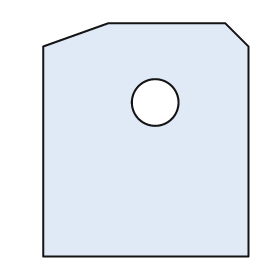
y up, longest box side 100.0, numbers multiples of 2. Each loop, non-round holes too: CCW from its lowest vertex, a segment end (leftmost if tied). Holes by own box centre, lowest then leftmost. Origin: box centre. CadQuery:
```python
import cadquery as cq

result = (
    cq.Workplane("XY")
    .moveTo(-44.0, -50.0)
    .lineTo(44.0, -50.0)
    .lineTo(44.0, 40.0)
    .lineTo(34.0, 50.0)
    .lineTo(-16.0, 50.0)
    .lineTo(-44.0, 40.0)
    .close()
    .moveTo(4.0, 16.0)
    .circle(10.0)
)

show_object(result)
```